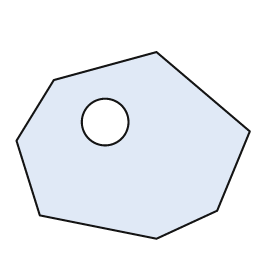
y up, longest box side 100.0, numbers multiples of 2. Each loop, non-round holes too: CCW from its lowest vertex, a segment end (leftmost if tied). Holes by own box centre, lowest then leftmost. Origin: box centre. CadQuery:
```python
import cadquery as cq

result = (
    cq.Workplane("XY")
    .moveTo(10.0, -40.0)
    .lineTo(36.0, -28.0)
    .lineTo(50.0, 6.0)
    .lineTo(10.0, 40.0)
    .lineTo(-34.0, 28.0)
    .lineTo(-50.0, 2.0)
    .lineTo(-40.0, -30.0)
    .close()
    .moveTo(-12.0, 10.0)
    .circle(10.0)
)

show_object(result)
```